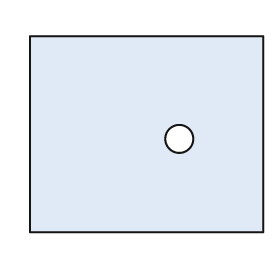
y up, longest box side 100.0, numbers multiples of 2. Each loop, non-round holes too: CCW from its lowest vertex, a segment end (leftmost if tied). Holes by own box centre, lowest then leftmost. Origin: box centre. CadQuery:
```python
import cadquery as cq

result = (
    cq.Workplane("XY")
    .moveTo(-50.0, -42.0)
    .lineTo(50.0, -42.0)
    .lineTo(50.0, 42.0)
    .lineTo(-50.0, 42.0)
    .close()
    .moveTo(14.0, -2.0)
    .circle(6.0)
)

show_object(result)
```